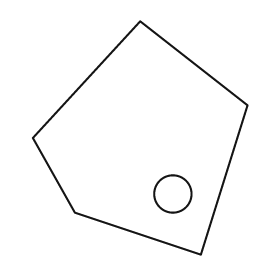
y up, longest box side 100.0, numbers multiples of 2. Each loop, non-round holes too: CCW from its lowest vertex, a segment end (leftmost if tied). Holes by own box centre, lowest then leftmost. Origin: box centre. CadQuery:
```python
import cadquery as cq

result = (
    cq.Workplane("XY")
    .moveTo(26.0, -50.0)
    .lineTo(46.0, 14.0)
    .lineTo(0.0, 50.0)
    .lineTo(-46.0, 0.0)
    .lineTo(-28.0, -32.0)
    .close()
    .moveTo(14.0, -24.0)
    .circle(8.0)
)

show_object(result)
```